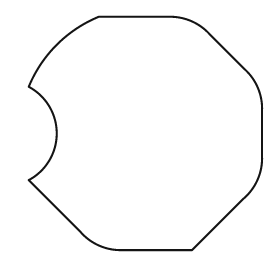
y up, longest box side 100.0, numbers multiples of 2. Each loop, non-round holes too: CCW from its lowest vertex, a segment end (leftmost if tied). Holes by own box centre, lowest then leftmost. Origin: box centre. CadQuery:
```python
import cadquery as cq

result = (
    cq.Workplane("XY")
    .moveTo(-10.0, -50.0)
    .lineTo(20.0, -50.0)
    .lineTo(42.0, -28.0)
    .threePointArc((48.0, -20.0), (50.0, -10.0))
    .lineTo(50.0, 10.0)
    .threePointArc((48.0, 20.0), (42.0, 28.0))
    .lineTo(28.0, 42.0)
    .threePointArc((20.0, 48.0), (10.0, 50.0))
    .lineTo(-20.0, 50.0)
    .threePointArc((-38.0, 38.0), (-50.0, 20.0))
    .threePointArc((-38.0, 0.0), (-50.0, -20.0))
    .lineTo(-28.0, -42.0)
    .threePointArc((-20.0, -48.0), (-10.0, -50.0))
    .close()
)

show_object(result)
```